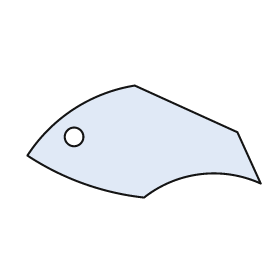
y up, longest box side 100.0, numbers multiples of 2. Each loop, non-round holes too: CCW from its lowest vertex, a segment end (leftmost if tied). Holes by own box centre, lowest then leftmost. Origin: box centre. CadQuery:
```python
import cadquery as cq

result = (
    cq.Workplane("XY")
    .moveTo(0.0, -24.0)
    .threePointArc((24.0, -14.0), (50.0, -18.0))
    .lineTo(40.0, 4.0)
    .lineTo(-4.0, 24.0)
    .threePointArc((-30.0, 14.0), (-50.0, -6.0))
    .threePointArc((-26.0, -18.0), (0.0, -24.0))
    .close()
    .moveTo(-30.0, 2.0)
    .circle(4.0)
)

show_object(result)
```